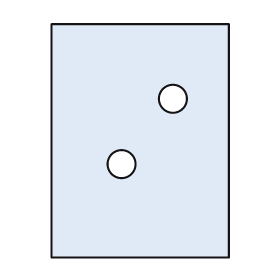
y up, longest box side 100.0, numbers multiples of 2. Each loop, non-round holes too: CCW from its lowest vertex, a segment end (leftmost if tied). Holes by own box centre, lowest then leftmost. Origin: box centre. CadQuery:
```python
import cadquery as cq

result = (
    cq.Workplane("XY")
    .moveTo(-38.0, -50.0)
    .lineTo(38.0, -50.0)
    .lineTo(38.0, 50.0)
    .lineTo(-38.0, 50.0)
    .close()
    .moveTo(-8.0, -10.0)
    .circle(6.0)
    .moveTo(14.0, 18.0)
    .circle(6.0)
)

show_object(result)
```